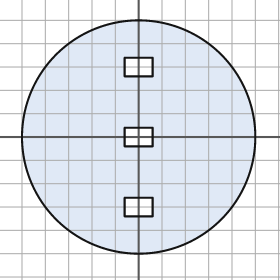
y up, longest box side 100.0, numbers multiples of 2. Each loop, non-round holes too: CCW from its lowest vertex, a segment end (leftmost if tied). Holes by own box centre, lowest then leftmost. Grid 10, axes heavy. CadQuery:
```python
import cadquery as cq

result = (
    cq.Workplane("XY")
    .moveTo(0.0, 0.0)
    .circle(50.0)
    .moveTo(-6.0, -34.0)
    .lineTo(6.0, -34.0)
    .lineTo(6.0, -26.0)
    .lineTo(-6.0, -26.0)
    .close()
    .moveTo(-6.0, -4.0)
    .lineTo(6.0, -4.0)
    .lineTo(6.0, 4.0)
    .lineTo(-6.0, 4.0)
    .close()
    .moveTo(-6.0, 26.0)
    .lineTo(6.0, 26.0)
    .lineTo(6.0, 34.0)
    .lineTo(-6.0, 34.0)
    .close()
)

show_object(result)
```